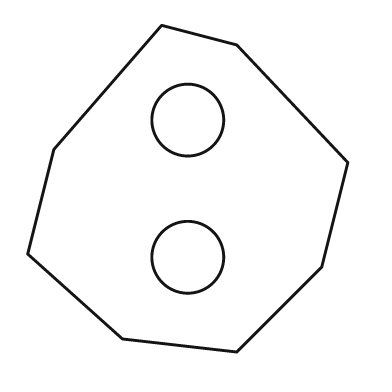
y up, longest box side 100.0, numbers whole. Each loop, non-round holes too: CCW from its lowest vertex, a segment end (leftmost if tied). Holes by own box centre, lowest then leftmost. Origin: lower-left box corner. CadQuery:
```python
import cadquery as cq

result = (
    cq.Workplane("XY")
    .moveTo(64.0, 0.0)
    .lineTo(90.0, 26.0)
    .lineTo(98.0, 58.0)
    .lineTo(64.0, 94.0)
    .lineTo(41.0, 100.0)
    .lineTo(8.0, 62.0)
    .lineTo(0.0, 30.0)
    .lineTo(29.0, 4.0)
    .close()
    .moveTo(49.0, 29.0)
    .circle(11.0)
    .moveTo(49.0, 71.0)
    .circle(11.0)
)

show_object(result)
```